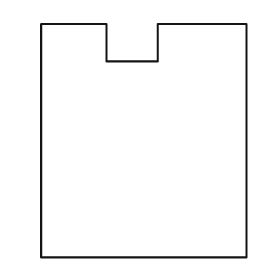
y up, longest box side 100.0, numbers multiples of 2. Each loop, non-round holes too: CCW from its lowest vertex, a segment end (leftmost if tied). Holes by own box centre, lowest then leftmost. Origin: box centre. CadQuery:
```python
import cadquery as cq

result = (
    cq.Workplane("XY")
    .moveTo(-44.0, -50.0)
    .lineTo(44.0, -50.0)
    .lineTo(44.0, 50.0)
    .lineTo(6.0, 50.0)
    .lineTo(6.0, 34.0)
    .lineTo(-16.0, 34.0)
    .lineTo(-16.0, 50.0)
    .lineTo(-44.0, 50.0)
    .close()
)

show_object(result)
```